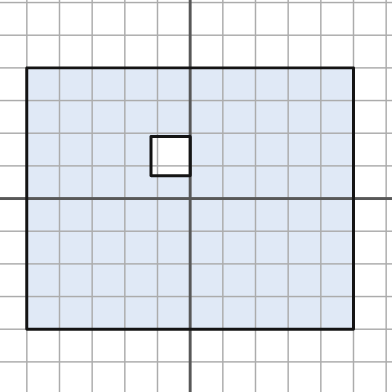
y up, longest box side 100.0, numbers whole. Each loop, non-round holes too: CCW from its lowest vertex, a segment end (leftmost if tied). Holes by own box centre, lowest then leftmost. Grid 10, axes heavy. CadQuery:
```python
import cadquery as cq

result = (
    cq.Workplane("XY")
    .moveTo(-50.0, -40.0)
    .lineTo(50.0, -40.0)
    .lineTo(50.0, 40.0)
    .lineTo(-50.0, 40.0)
    .close()
    .moveTo(-12.0, 7.0)
    .lineTo(0.0, 7.0)
    .lineTo(0.0, 19.0)
    .lineTo(-12.0, 19.0)
    .close()
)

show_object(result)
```